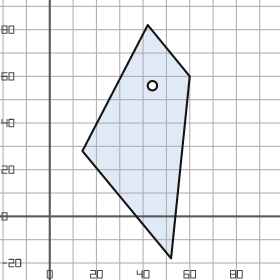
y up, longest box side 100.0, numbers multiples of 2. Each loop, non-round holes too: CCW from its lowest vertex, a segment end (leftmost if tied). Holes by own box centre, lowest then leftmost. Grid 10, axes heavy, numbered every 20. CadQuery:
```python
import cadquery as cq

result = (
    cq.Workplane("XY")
    .moveTo(52.0, -18.0)
    .lineTo(60.0, 60.0)
    .lineTo(42.0, 82.0)
    .lineTo(14.0, 28.0)
    .close()
    .moveTo(44.0, 56.0)
    .circle(2.0)
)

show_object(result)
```